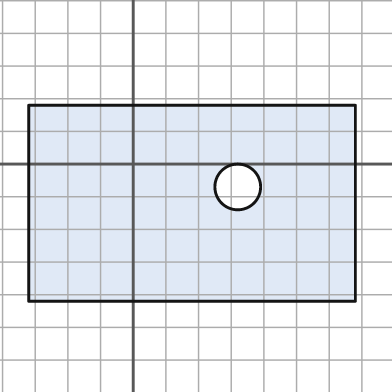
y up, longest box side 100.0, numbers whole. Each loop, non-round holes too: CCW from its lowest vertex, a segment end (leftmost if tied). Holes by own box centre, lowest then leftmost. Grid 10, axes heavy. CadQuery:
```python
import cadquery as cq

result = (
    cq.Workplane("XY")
    .moveTo(-32.0, -42.0)
    .lineTo(68.0, -42.0)
    .lineTo(68.0, 18.0)
    .lineTo(-32.0, 18.0)
    .close()
    .moveTo(32.0, -7.0)
    .circle(7.0)
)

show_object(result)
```